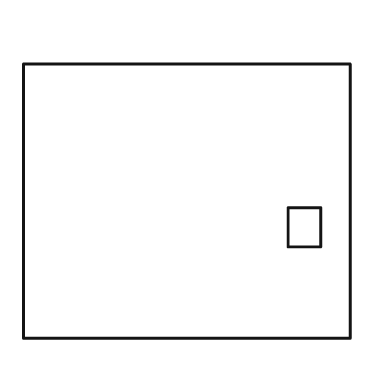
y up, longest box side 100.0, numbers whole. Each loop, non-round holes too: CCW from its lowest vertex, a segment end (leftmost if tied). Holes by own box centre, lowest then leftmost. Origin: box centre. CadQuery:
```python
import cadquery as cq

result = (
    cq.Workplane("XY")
    .moveTo(-50.0, -42.0)
    .lineTo(50.0, -42.0)
    .lineTo(50.0, 42.0)
    .lineTo(-50.0, 42.0)
    .close()
    .moveTo(31.0, -14.0)
    .lineTo(41.0, -14.0)
    .lineTo(41.0, -2.0)
    .lineTo(31.0, -2.0)
    .close()
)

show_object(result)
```